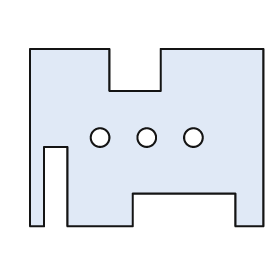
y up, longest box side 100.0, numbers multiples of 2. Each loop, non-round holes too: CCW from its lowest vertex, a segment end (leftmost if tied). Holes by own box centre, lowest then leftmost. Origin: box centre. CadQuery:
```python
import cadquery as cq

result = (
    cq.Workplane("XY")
    .moveTo(-50.0, -38.0)
    .lineTo(-44.0, -38.0)
    .lineTo(-44.0, -4.0)
    .lineTo(-34.0, -4.0)
    .lineTo(-34.0, -38.0)
    .lineTo(-6.0, -38.0)
    .lineTo(-6.0, -24.0)
    .lineTo(38.0, -24.0)
    .lineTo(38.0, -38.0)
    .lineTo(50.0, -38.0)
    .lineTo(50.0, 38.0)
    .lineTo(6.0, 38.0)
    .lineTo(6.0, 20.0)
    .lineTo(-16.0, 20.0)
    .lineTo(-16.0, 38.0)
    .lineTo(-50.0, 38.0)
    .close()
    .moveTo(-20.0, 0.0)
    .circle(4.0)
    .moveTo(0.0, 0.0)
    .circle(4.0)
    .moveTo(20.0, 0.0)
    .circle(4.0)
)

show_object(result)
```